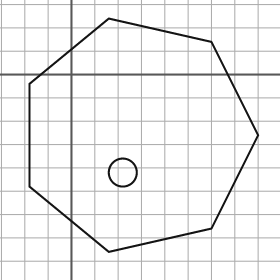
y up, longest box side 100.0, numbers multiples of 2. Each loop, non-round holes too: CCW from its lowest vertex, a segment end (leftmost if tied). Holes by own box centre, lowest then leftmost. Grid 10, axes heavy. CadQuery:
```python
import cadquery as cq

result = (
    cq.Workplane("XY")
    .moveTo(16.0, -76.0)
    .lineTo(60.0, -66.0)
    .lineTo(80.0, -26.0)
    .lineTo(60.0, 14.0)
    .lineTo(16.0, 24.0)
    .lineTo(-18.0, -4.0)
    .lineTo(-18.0, -48.0)
    .close()
    .moveTo(22.0, -42.0)
    .circle(6.0)
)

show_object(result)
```